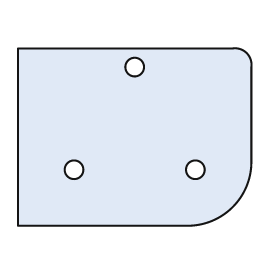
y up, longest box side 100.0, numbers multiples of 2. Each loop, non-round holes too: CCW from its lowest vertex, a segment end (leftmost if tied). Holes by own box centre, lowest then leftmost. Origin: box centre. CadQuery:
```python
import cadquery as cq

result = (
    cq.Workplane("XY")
    .moveTo(-50.0, -38.0)
    .lineTo(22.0, -38.0)
    .threePointArc((42.0, -30.0), (50.0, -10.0))
    .lineTo(50.0, 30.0)
    .threePointArc((48.0, 36.0), (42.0, 38.0))
    .lineTo(-50.0, 38.0)
    .close()
    .moveTo(-26.0, -14.0)
    .circle(4.0)
    .moveTo(26.0, -14.0)
    .circle(4.0)
    .moveTo(0.0, 30.0)
    .circle(4.0)
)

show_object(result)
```